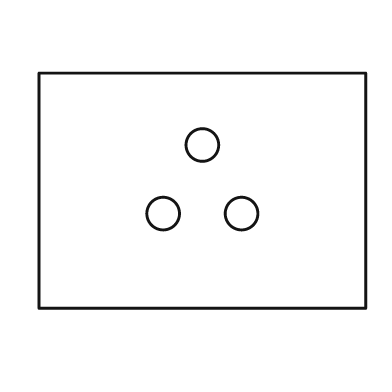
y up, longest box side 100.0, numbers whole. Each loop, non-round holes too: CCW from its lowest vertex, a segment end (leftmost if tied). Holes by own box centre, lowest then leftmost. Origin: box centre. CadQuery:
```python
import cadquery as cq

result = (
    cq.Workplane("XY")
    .moveTo(-50.0, -36.0)
    .lineTo(50.0, -36.0)
    .lineTo(50.0, 36.0)
    .lineTo(-50.0, 36.0)
    .close()
    .moveTo(-12.0, -7.0)
    .circle(5.0)
    .moveTo(12.0, -7.0)
    .circle(5.0)
    .moveTo(0.0, 14.0)
    .circle(5.0)
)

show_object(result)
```